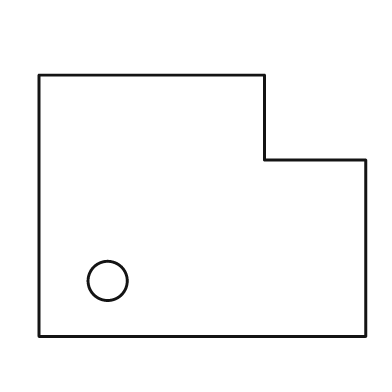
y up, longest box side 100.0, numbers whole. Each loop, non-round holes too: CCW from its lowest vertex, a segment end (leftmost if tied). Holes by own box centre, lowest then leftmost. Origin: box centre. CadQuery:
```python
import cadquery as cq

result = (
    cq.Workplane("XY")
    .moveTo(-50.0, -40.0)
    .lineTo(50.0, -40.0)
    .lineTo(50.0, 14.0)
    .lineTo(19.0, 14.0)
    .lineTo(19.0, 40.0)
    .lineTo(-50.0, 40.0)
    .close()
    .moveTo(-29.0, -23.0)
    .circle(6.0)
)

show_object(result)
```